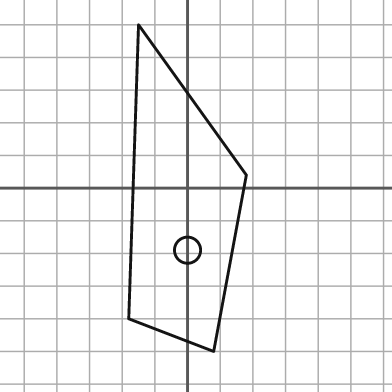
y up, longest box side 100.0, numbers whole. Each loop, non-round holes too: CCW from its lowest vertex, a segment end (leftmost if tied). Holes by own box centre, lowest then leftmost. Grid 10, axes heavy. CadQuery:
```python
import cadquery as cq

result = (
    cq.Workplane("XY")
    .moveTo(8.0, -50.0)
    .lineTo(18.0, 4.0)
    .lineTo(-15.0, 50.0)
    .lineTo(-18.0, -40.0)
    .close()
    .moveTo(0.0, -19.0)
    .circle(4.0)
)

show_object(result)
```